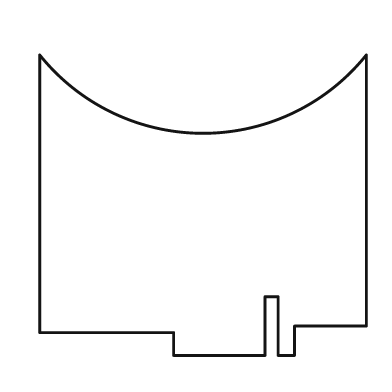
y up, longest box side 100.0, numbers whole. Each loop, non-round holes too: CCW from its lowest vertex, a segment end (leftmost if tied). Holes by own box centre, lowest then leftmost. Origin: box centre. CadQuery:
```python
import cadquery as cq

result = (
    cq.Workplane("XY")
    .moveTo(-9.0, -46.0)
    .lineTo(19.0, -46.0)
    .lineTo(19.0, -28.0)
    .lineTo(23.0, -28.0)
    .lineTo(23.0, -46.0)
    .lineTo(28.0, -46.0)
    .lineTo(28.0, -37.0)
    .lineTo(50.0, -37.0)
    .lineTo(50.0, 46.0)
    .threePointArc((0.0, 22.0), (-50.0, 46.0))
    .lineTo(-50.0, -39.0)
    .lineTo(-9.0, -39.0)
    .close()
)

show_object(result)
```